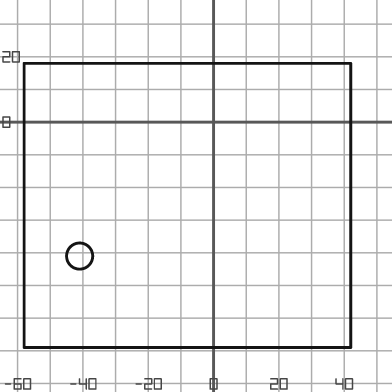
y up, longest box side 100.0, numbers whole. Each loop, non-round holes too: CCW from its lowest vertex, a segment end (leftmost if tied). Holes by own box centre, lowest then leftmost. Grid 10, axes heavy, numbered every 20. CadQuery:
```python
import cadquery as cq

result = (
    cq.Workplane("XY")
    .moveTo(-58.0, -69.0)
    .lineTo(42.0, -69.0)
    .lineTo(42.0, 18.0)
    .lineTo(-58.0, 18.0)
    .close()
    .moveTo(-41.0, -41.0)
    .circle(4.0)
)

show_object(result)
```